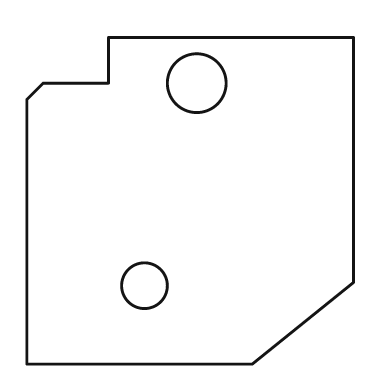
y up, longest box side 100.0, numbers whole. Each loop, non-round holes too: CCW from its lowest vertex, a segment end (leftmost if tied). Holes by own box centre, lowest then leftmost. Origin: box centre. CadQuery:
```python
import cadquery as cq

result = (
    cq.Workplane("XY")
    .moveTo(-50.0, -50.0)
    .lineTo(19.0, -50.0)
    .lineTo(50.0, -25.0)
    .lineTo(50.0, 50.0)
    .lineTo(-25.0, 50.0)
    .lineTo(-25.0, 36.0)
    .lineTo(-45.0, 36.0)
    .lineTo(-50.0, 31.0)
    .close()
    .moveTo(-14.0, -26.0)
    .circle(7.0)
    .moveTo(2.0, 36.0)
    .circle(9.0)
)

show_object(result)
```